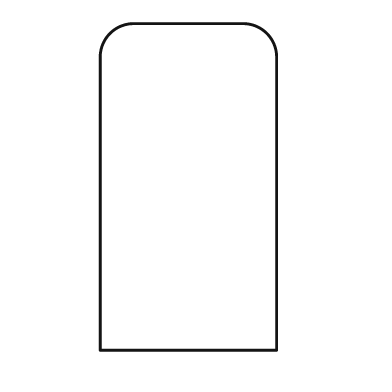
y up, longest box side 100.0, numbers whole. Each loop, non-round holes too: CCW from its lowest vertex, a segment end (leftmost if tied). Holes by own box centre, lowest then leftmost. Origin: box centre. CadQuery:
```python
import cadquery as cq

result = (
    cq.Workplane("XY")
    .moveTo(-27.0, -50.0)
    .lineTo(27.0, -50.0)
    .lineTo(27.0, 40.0)
    .threePointArc((24.0, 47.0), (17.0, 50.0))
    .lineTo(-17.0, 50.0)
    .threePointArc((-24.0, 47.0), (-27.0, 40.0))
    .close()
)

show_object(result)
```